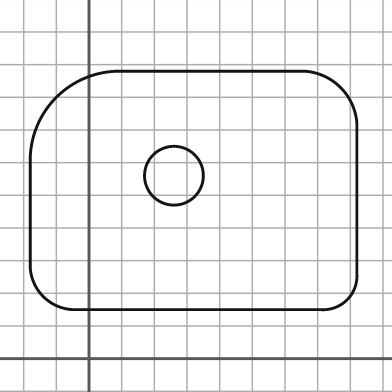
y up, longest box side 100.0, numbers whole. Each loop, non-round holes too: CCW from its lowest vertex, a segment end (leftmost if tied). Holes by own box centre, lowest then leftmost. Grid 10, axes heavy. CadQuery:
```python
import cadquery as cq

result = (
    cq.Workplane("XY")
    .moveTo(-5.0, 15.0)
    .lineTo(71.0, 15.0)
    .threePointArc((79.0, 18.0), (82.0, 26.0))
    .lineTo(82.0, 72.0)
    .threePointArc((77.0, 83.0), (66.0, 88.0))
    .lineTo(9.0, 88.0)
    .threePointArc((-10.0, 80.0), (-18.0, 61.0))
    .lineTo(-18.0, 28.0)
    .threePointArc((-14.0, 19.0), (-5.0, 15.0))
    .close()
    .moveTo(26.0, 56.0)
    .circle(9.0)
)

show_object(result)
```